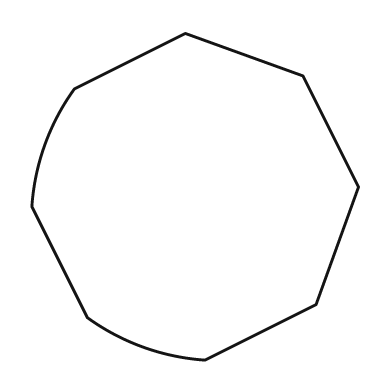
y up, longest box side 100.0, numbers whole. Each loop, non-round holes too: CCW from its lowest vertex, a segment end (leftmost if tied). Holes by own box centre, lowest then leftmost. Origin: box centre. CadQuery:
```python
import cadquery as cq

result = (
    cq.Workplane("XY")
    .moveTo(3.0, -50.0)
    .lineTo(37.0, -33.0)
    .lineTo(50.0, 3.0)
    .lineTo(33.0, 37.0)
    .lineTo(-3.0, 50.0)
    .lineTo(-37.0, 33.0)
    .threePointArc((-46.0, 16.0), (-50.0, -3.0))
    .lineTo(-33.0, -37.0)
    .threePointArc((-16.0, -46.0), (3.0, -50.0))
    .close()
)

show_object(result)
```